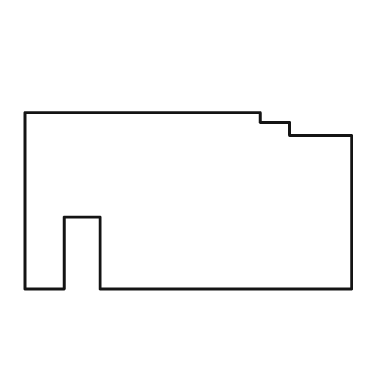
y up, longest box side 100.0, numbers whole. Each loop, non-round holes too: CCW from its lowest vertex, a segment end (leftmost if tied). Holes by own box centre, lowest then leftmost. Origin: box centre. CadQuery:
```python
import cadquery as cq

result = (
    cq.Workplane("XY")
    .moveTo(-50.0, -27.0)
    .lineTo(-38.0, -27.0)
    .lineTo(-38.0, -5.0)
    .lineTo(-27.0, -5.0)
    .lineTo(-27.0, -27.0)
    .lineTo(50.0, -27.0)
    .lineTo(50.0, 20.0)
    .lineTo(31.0, 20.0)
    .lineTo(31.0, 24.0)
    .lineTo(22.0, 24.0)
    .lineTo(22.0, 27.0)
    .lineTo(-50.0, 27.0)
    .close()
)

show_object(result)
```